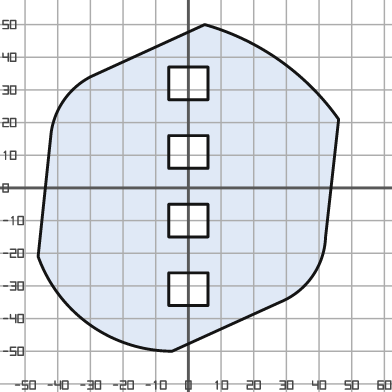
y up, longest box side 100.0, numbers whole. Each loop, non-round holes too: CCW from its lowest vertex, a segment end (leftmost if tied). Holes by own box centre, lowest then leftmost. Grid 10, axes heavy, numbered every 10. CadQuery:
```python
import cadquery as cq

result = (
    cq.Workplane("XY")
    .moveTo(-5.0, -50.0)
    .lineTo(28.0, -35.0)
    .threePointArc((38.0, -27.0), (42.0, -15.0))
    .lineTo(46.0, 21.0)
    .threePointArc((28.0, 39.0), (5.0, 50.0))
    .lineTo(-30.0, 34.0)
    .threePointArc((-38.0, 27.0), (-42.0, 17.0))
    .lineTo(-46.0, -21.0)
    .threePointArc((-30.0, -42.0), (-5.0, -50.0))
    .close()
    .moveTo(-6.0, -36.0)
    .lineTo(6.0, -36.0)
    .lineTo(6.0, -26.0)
    .lineTo(-6.0, -26.0)
    .close()
    .moveTo(-6.0, -15.0)
    .lineTo(6.0, -15.0)
    .lineTo(6.0, -5.0)
    .lineTo(-6.0, -5.0)
    .close()
    .moveTo(-6.0, 6.0)
    .lineTo(6.0, 6.0)
    .lineTo(6.0, 16.0)
    .lineTo(-6.0, 16.0)
    .close()
    .moveTo(-6.0, 27.0)
    .lineTo(6.0, 27.0)
    .lineTo(6.0, 37.0)
    .lineTo(-6.0, 37.0)
    .close()
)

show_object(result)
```